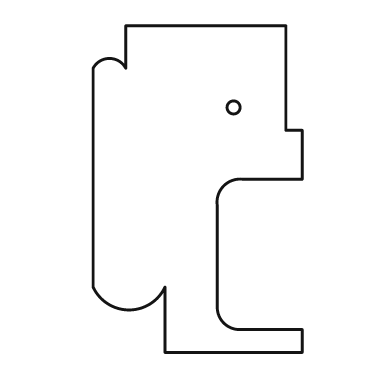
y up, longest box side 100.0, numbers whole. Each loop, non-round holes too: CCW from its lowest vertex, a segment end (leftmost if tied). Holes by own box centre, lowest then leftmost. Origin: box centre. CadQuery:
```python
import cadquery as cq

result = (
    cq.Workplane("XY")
    .moveTo(-10.0, -50.0)
    .lineTo(32.0, -50.0)
    .lineTo(32.0, -43.0)
    .lineTo(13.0, -43.0)
    .threePointArc((8.0, -41.0), (6.0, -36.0))
    .lineTo(6.0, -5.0)
    .threePointArc((8.0, 1.0), (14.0, 3.0))
    .lineTo(32.0, 3.0)
    .lineTo(32.0, 18.0)
    .lineTo(27.0, 18.0)
    .lineTo(27.0, 50.0)
    .lineTo(-22.0, 50.0)
    .lineTo(-22.0, 37.0)
    .threePointArc((-27.0, 40.0), (-32.0, 37.0))
    .lineTo(-32.0, -30.0)
    .threePointArc((-21.0, -37.0), (-10.0, -30.0))
    .close()
    .moveTo(11.0, 25.0)
    .circle(2.0)
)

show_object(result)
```